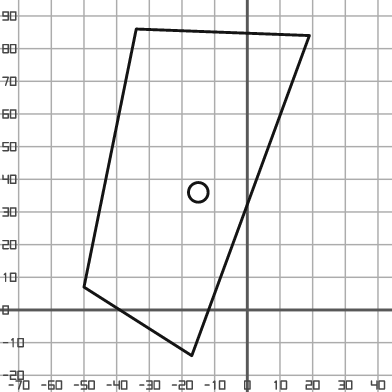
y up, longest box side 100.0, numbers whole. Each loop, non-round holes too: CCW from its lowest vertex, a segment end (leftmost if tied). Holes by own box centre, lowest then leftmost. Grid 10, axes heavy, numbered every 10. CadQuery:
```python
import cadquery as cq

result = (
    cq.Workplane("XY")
    .moveTo(-17.0, -14.0)
    .lineTo(19.0, 84.0)
    .lineTo(-34.0, 86.0)
    .lineTo(-50.0, 7.0)
    .close()
    .moveTo(-15.0, 36.0)
    .circle(3.0)
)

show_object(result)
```